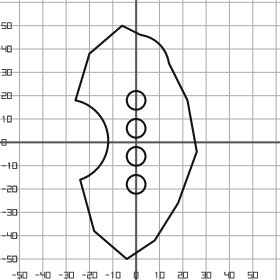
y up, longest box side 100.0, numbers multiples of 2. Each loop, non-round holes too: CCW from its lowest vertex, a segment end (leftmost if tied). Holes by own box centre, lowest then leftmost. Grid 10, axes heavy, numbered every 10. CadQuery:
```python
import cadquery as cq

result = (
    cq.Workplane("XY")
    .moveTo(-4.0, -50.0)
    .lineTo(8.0, -42.0)
    .lineTo(18.0, -26.0)
    .lineTo(26.0, -4.0)
    .lineTo(22.0, 18.0)
    .lineTo(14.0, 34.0)
    .threePointArc((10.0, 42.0), (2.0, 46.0))
    .lineTo(-6.0, 50.0)
    .lineTo(-20.0, 38.0)
    .lineTo(-26.0, 18.0)
    .threePointArc((-12.0, 2.0), (-24.0, -16.0))
    .lineTo(-18.0, -38.0)
    .close()
    .moveTo(0.0, -18.0)
    .circle(4.0)
    .moveTo(0.0, -6.0)
    .circle(4.0)
    .moveTo(0.0, 6.0)
    .circle(4.0)
    .moveTo(0.0, 18.0)
    .circle(4.0)
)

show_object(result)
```